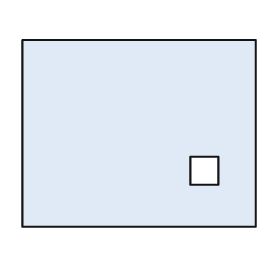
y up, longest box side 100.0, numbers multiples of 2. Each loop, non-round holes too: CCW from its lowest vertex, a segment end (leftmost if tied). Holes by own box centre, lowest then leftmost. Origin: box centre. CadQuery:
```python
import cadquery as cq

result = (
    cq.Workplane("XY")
    .moveTo(-50.0, -40.0)
    .lineTo(50.0, -40.0)
    .lineTo(50.0, 40.0)
    .lineTo(-50.0, 40.0)
    .close()
    .moveTo(22.0, -22.0)
    .lineTo(34.0, -22.0)
    .lineTo(34.0, -10.0)
    .lineTo(22.0, -10.0)
    .close()
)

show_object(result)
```